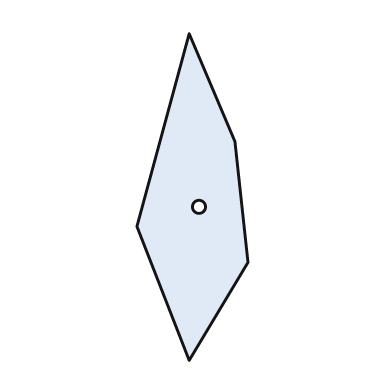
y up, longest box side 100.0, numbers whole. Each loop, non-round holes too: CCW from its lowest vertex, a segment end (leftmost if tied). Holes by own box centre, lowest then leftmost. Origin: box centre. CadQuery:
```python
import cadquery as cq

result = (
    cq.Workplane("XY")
    .moveTo(-1.0, -50.0)
    .lineTo(17.0, -20.0)
    .lineTo(13.0, 17.0)
    .lineTo(-1.0, 50.0)
    .lineTo(-17.0, -9.0)
    .close()
    .moveTo(2.0, -3.0)
    .circle(2.0)
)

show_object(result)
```